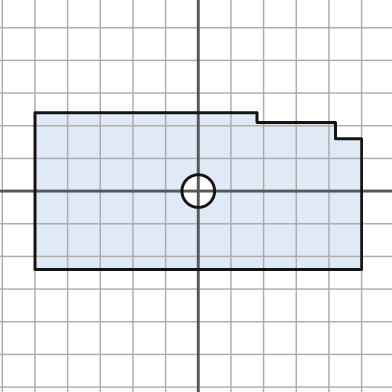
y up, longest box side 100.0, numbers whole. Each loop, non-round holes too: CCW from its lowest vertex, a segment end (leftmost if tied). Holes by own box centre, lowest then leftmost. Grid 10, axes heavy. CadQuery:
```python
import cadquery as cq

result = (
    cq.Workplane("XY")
    .moveTo(-50.0, -24.0)
    .lineTo(50.0, -24.0)
    .lineTo(50.0, 16.0)
    .lineTo(42.0, 16.0)
    .lineTo(42.0, 21.0)
    .lineTo(18.0, 21.0)
    .lineTo(18.0, 24.0)
    .lineTo(-50.0, 24.0)
    .close()
    .moveTo(0.0, 0.0)
    .circle(5.0)
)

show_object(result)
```